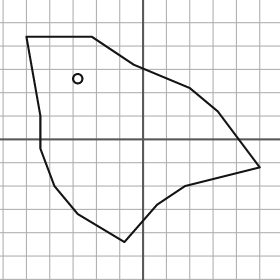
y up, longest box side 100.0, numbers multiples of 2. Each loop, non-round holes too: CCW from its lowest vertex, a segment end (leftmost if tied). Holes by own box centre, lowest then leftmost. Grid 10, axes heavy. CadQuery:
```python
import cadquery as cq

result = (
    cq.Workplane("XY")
    .moveTo(-8.0, -44.0)
    .lineTo(6.0, -28.0)
    .lineTo(18.0, -20.0)
    .lineTo(50.0, -12.0)
    .lineTo(32.0, 12.0)
    .lineTo(20.0, 22.0)
    .lineTo(-4.0, 32.0)
    .lineTo(-22.0, 44.0)
    .lineTo(-50.0, 44.0)
    .lineTo(-44.0, 10.0)
    .lineTo(-44.0, -4.0)
    .lineTo(-38.0, -20.0)
    .lineTo(-28.0, -32.0)
    .close()
    .moveTo(-28.0, 26.0)
    .circle(2.0)
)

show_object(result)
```